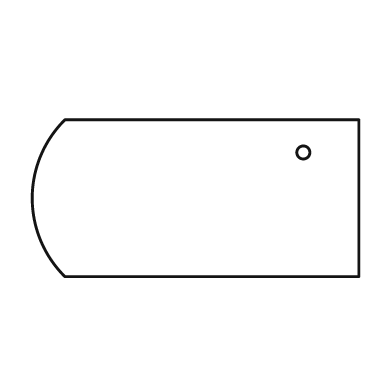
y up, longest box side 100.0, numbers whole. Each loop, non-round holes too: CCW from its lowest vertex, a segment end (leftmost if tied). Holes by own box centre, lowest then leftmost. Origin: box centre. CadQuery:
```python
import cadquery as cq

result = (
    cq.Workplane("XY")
    .moveTo(-40.0, -24.0)
    .lineTo(50.0, -24.0)
    .lineTo(50.0, 24.0)
    .lineTo(-40.0, 24.0)
    .threePointArc((-50.0, 0.0), (-40.0, -24.0))
    .close()
    .moveTo(33.0, 14.0)
    .circle(2.0)
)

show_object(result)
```